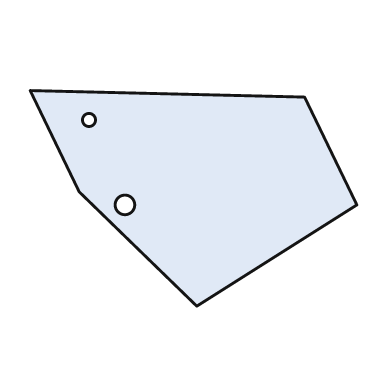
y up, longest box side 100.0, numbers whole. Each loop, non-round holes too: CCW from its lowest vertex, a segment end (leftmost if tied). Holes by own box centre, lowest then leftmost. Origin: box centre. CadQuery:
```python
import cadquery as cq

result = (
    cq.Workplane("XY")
    .moveTo(1.0, -33.0)
    .lineTo(50.0, -2.0)
    .lineTo(34.0, 31.0)
    .lineTo(-50.0, 33.0)
    .lineTo(-35.0, 2.0)
    .close()
    .moveTo(-21.0, -2.0)
    .circle(3.0)
    .moveTo(-32.0, 24.0)
    .circle(2.0)
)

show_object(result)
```